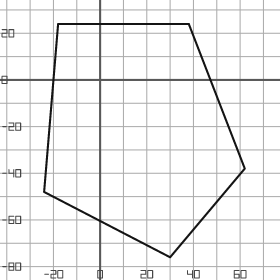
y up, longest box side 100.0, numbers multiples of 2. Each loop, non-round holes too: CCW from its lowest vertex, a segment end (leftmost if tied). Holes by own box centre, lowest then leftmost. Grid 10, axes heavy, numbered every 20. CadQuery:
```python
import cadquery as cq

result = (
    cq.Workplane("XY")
    .moveTo(30.0, -76.0)
    .lineTo(62.0, -38.0)
    .lineTo(38.0, 24.0)
    .lineTo(-18.0, 24.0)
    .lineTo(-24.0, -48.0)
    .close()
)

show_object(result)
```